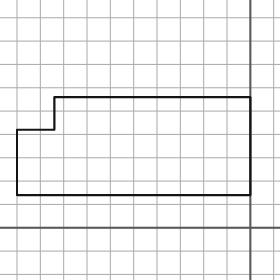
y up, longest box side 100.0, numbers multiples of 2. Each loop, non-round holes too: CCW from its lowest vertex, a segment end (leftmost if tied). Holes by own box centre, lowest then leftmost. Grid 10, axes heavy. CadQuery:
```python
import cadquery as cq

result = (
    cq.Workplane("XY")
    .moveTo(-100.0, 14.0)
    .lineTo(0.0, 14.0)
    .lineTo(0.0, 56.0)
    .lineTo(-84.0, 56.0)
    .lineTo(-84.0, 42.0)
    .lineTo(-100.0, 42.0)
    .close()
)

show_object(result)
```